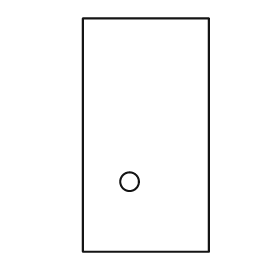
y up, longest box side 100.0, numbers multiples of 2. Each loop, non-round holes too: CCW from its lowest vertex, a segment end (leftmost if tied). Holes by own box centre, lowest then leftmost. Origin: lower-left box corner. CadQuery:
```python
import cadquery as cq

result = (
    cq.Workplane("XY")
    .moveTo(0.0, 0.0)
    .lineTo(54.0, 0.0)
    .lineTo(54.0, 100.0)
    .lineTo(0.0, 100.0)
    .close()
    .moveTo(20.0, 30.0)
    .circle(4.0)
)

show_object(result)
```